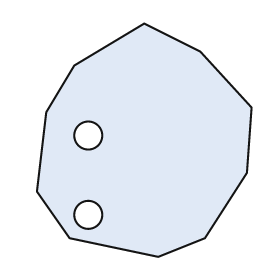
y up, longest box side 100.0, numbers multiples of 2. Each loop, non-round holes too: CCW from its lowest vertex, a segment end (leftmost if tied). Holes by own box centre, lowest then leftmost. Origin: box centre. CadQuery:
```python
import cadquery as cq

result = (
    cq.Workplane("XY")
    .moveTo(6.0, -50.0)
    .lineTo(26.0, -42.0)
    .lineTo(44.0, -14.0)
    .lineTo(46.0, 14.0)
    .lineTo(24.0, 38.0)
    .lineTo(0.0, 50.0)
    .lineTo(-30.0, 32.0)
    .lineTo(-42.0, 12.0)
    .lineTo(-46.0, -22.0)
    .lineTo(-32.0, -42.0)
    .close()
    .moveTo(-24.0, -32.0)
    .circle(6.0)
    .moveTo(-24.0, 2.0)
    .circle(6.0)
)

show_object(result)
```